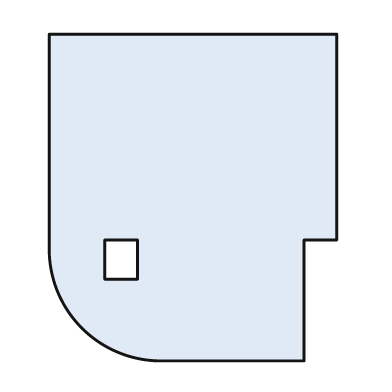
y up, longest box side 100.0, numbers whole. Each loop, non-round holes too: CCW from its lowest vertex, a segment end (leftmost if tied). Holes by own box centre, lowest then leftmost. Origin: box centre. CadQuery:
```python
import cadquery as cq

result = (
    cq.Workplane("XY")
    .moveTo(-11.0, -50.0)
    .lineTo(34.0, -50.0)
    .lineTo(34.0, -13.0)
    .lineTo(44.0, -13.0)
    .lineTo(44.0, 50.0)
    .lineTo(-44.0, 50.0)
    .lineTo(-44.0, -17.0)
    .threePointArc((-34.0, -40.0), (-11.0, -50.0))
    .close()
    .moveTo(-27.0, -25.0)
    .lineTo(-17.0, -25.0)
    .lineTo(-17.0, -13.0)
    .lineTo(-27.0, -13.0)
    .close()
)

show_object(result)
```